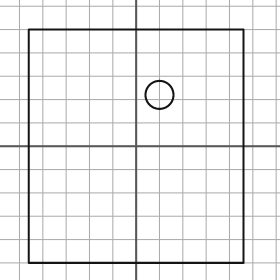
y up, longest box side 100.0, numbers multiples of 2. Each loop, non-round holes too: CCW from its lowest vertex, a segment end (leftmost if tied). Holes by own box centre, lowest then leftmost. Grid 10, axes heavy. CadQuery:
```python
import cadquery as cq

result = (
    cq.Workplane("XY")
    .moveTo(-46.0, -50.0)
    .lineTo(46.0, -50.0)
    .lineTo(46.0, 50.0)
    .lineTo(-46.0, 50.0)
    .close()
    .moveTo(10.0, 22.0)
    .circle(6.0)
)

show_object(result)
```